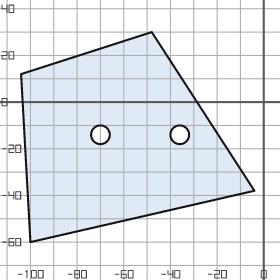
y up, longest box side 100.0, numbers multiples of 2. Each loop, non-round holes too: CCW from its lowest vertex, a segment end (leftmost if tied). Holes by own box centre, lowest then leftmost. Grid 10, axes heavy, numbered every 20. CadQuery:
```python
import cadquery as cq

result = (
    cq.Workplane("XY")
    .moveTo(-100.0, -60.0)
    .lineTo(-4.0, -38.0)
    .lineTo(-48.0, 30.0)
    .lineTo(-104.0, 12.0)
    .close()
    .moveTo(-70.0, -14.0)
    .circle(4.0)
    .moveTo(-36.0, -14.0)
    .circle(4.0)
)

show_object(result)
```